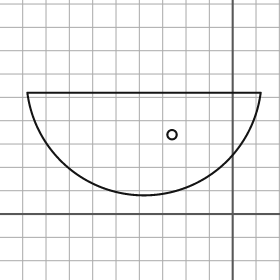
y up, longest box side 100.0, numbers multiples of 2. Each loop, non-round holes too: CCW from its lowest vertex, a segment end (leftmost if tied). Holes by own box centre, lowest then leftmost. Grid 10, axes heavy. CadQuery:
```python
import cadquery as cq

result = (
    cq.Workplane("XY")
    .moveTo(-88.0, 52.0)
    .threePointArc((-38.0, 8.0), (12.0, 52.0))
    .close()
    .moveTo(-26.0, 34.0)
    .circle(2.0)
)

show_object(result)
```